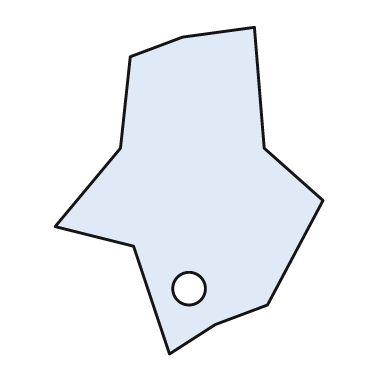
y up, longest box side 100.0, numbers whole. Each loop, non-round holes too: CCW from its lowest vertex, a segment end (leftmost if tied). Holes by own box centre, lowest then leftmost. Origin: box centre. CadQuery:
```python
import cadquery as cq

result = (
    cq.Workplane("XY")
    .moveTo(-6.0, -50.0)
    .lineTo(8.0, -41.0)
    .lineTo(24.0, -35.0)
    .lineTo(41.0, -3.0)
    .lineTo(23.0, 13.0)
    .lineTo(20.0, 50.0)
    .lineTo(-2.0, 47.0)
    .lineTo(-18.0, 41.0)
    .lineTo(-21.0, 13.0)
    .lineTo(-41.0, -11.0)
    .lineTo(-17.0, -17.0)
    .close()
    .moveTo(0.0, -30.0)
    .circle(5.0)
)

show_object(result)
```